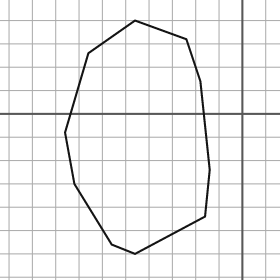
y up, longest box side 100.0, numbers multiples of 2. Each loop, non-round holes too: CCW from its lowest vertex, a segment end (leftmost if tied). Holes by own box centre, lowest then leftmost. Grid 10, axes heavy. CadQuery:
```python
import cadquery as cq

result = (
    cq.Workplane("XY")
    .moveTo(-46.0, -60.0)
    .lineTo(-16.0, -44.0)
    .lineTo(-14.0, -24.0)
    .lineTo(-18.0, 14.0)
    .lineTo(-24.0, 32.0)
    .lineTo(-46.0, 40.0)
    .lineTo(-66.0, 26.0)
    .lineTo(-76.0, -8.0)
    .lineTo(-72.0, -30.0)
    .lineTo(-56.0, -56.0)
    .close()
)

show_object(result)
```